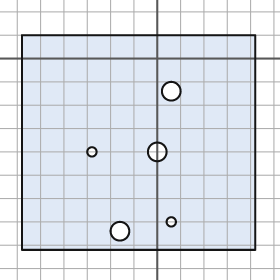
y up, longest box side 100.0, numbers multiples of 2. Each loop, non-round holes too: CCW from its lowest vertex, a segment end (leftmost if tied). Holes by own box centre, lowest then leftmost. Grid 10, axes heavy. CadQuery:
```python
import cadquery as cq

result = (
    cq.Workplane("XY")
    .moveTo(-58.0, -82.0)
    .lineTo(42.0, -82.0)
    .lineTo(42.0, 10.0)
    .lineTo(-58.0, 10.0)
    .close()
    .moveTo(-16.0, -74.0)
    .circle(4.0)
    .moveTo(6.0, -70.0)
    .circle(2.0)
    .moveTo(-28.0, -40.0)
    .circle(2.0)
    .moveTo(0.0, -40.0)
    .circle(4.0)
    .moveTo(6.0, -14.0)
    .circle(4.0)
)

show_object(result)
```